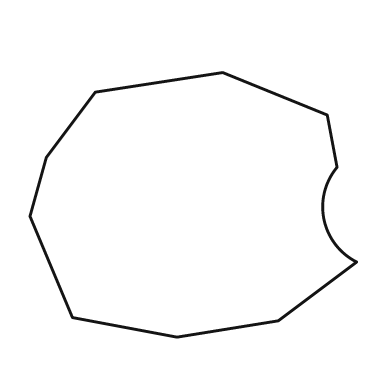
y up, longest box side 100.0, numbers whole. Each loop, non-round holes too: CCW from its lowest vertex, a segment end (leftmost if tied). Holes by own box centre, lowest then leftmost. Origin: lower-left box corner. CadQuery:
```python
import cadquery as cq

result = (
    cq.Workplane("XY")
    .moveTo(45.0, 0.0)
    .lineTo(76.0, 5.0)
    .lineTo(100.0, 23.0)
    .threePointArc((90.0, 36.0), (94.0, 52.0))
    .lineTo(91.0, 68.0)
    .lineTo(59.0, 81.0)
    .lineTo(20.0, 75.0)
    .lineTo(5.0, 55.0)
    .lineTo(0.0, 37.0)
    .lineTo(13.0, 6.0)
    .close()
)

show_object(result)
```